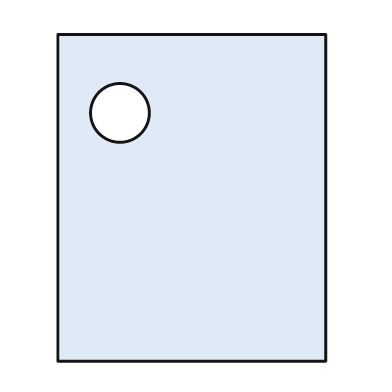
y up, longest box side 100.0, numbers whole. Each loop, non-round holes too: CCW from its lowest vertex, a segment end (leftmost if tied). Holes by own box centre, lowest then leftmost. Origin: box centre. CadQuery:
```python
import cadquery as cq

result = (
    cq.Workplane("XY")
    .moveTo(-41.0, -50.0)
    .lineTo(41.0, -50.0)
    .lineTo(41.0, 50.0)
    .lineTo(-41.0, 50.0)
    .close()
    .moveTo(-22.0, 26.0)
    .circle(9.0)
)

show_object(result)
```